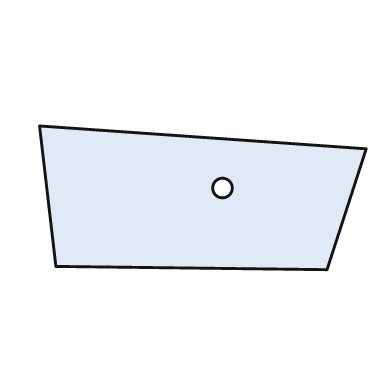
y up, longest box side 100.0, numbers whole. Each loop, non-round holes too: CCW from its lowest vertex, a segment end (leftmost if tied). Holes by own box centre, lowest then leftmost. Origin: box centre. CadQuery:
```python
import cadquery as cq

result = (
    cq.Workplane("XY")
    .moveTo(38.0, -22.0)
    .lineTo(50.0, 15.0)
    .lineTo(-50.0, 22.0)
    .lineTo(-45.0, -21.0)
    .close()
    .moveTo(6.0, 3.0)
    .circle(3.0)
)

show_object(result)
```